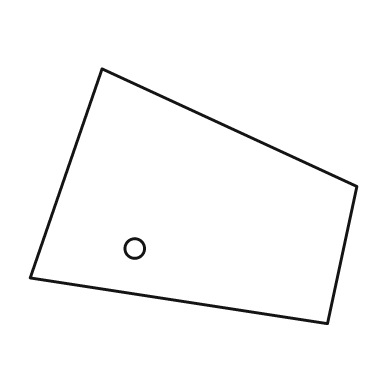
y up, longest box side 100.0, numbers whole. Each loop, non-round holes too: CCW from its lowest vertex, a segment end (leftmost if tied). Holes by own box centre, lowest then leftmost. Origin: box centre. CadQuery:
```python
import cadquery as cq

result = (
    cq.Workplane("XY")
    .moveTo(41.0, -39.0)
    .lineTo(50.0, 3.0)
    .lineTo(-28.0, 39.0)
    .lineTo(-50.0, -25.0)
    .close()
    .moveTo(-18.0, -16.0)
    .circle(3.0)
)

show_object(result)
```